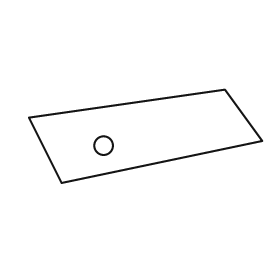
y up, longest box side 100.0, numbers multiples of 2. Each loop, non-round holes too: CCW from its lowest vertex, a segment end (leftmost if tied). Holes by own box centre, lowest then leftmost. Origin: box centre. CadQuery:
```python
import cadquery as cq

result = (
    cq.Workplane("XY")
    .moveTo(-36.0, -20.0)
    .lineTo(50.0, -2.0)
    .lineTo(34.0, 20.0)
    .lineTo(-50.0, 8.0)
    .close()
    .moveTo(-18.0, -4.0)
    .circle(4.0)
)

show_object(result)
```